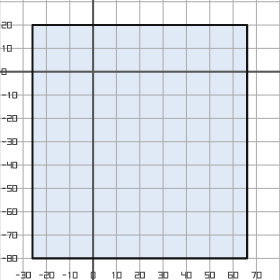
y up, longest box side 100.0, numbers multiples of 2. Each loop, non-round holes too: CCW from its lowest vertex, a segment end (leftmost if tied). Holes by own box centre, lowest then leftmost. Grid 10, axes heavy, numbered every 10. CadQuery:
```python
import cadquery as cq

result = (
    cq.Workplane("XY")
    .moveTo(-26.0, -80.0)
    .lineTo(66.0, -80.0)
    .lineTo(66.0, 20.0)
    .lineTo(-26.0, 20.0)
    .close()
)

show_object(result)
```